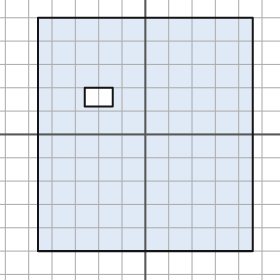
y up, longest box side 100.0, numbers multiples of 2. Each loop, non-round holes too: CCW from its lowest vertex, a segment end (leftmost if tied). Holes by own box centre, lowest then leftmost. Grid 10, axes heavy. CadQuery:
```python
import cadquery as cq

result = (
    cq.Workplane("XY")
    .moveTo(-46.0, -50.0)
    .lineTo(46.0, -50.0)
    .lineTo(46.0, 50.0)
    .lineTo(-46.0, 50.0)
    .close()
    .moveTo(-26.0, 12.0)
    .lineTo(-14.0, 12.0)
    .lineTo(-14.0, 20.0)
    .lineTo(-26.0, 20.0)
    .close()
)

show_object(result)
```